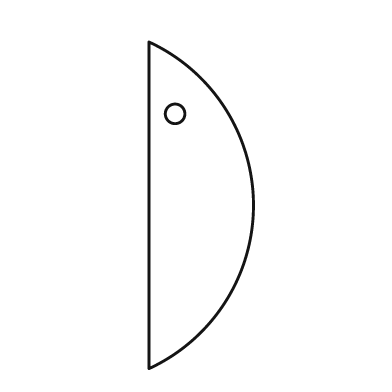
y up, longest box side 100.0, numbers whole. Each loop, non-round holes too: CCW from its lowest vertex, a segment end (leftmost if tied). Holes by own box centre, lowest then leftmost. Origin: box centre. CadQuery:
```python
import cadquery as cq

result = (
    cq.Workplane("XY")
    .moveTo(-16.0, -50.0)
    .threePointArc((16.0, 0.0), (-16.0, 50.0))
    .close()
    .moveTo(-8.0, 28.0)
    .circle(3.0)
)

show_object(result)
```